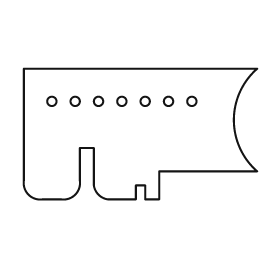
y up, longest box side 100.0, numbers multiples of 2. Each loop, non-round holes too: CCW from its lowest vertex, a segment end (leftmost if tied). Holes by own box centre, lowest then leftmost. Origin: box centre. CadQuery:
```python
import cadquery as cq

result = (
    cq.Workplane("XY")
    .moveTo(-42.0, -28.0)
    .lineTo(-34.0, -28.0)
    .threePointArc((-28.0, -26.0), (-26.0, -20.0))
    .lineTo(-26.0, -6.0)
    .lineTo(-20.0, -6.0)
    .lineTo(-20.0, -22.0)
    .threePointArc((-18.0, -26.0), (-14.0, -28.0))
    .lineTo(-2.0, -28.0)
    .lineTo(-2.0, -22.0)
    .lineTo(2.0, -22.0)
    .lineTo(2.0, -28.0)
    .lineTo(8.0, -28.0)
    .lineTo(8.0, -16.0)
    .lineTo(50.0, -16.0)
    .threePointArc((40.0, 6.0), (50.0, 28.0))
    .lineTo(-50.0, 28.0)
    .lineTo(-50.0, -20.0)
    .threePointArc((-48.0, -26.0), (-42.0, -28.0))
    .close()
    .moveTo(-38.0, 14.0)
    .circle(2.0)
    .moveTo(-28.0, 14.0)
    .circle(2.0)
    .moveTo(-18.0, 14.0)
    .circle(2.0)
    .moveTo(-8.0, 14.0)
    .circle(2.0)
    .moveTo(2.0, 14.0)
    .circle(2.0)
    .moveTo(12.0, 14.0)
    .circle(2.0)
    .moveTo(22.0, 14.0)
    .circle(2.0)
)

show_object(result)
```